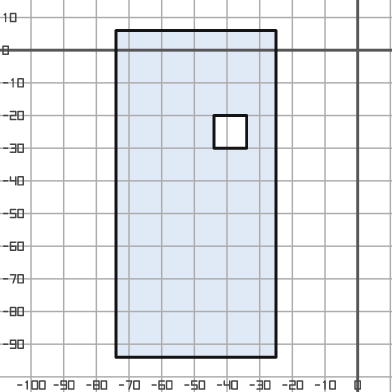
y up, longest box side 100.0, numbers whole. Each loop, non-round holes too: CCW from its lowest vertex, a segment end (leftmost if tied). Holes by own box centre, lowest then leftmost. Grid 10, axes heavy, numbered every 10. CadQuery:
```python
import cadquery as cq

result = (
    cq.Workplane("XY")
    .moveTo(-74.0, -94.0)
    .lineTo(-25.0, -94.0)
    .lineTo(-25.0, 6.0)
    .lineTo(-74.0, 6.0)
    .close()
    .moveTo(-44.0, -30.0)
    .lineTo(-34.0, -30.0)
    .lineTo(-34.0, -20.0)
    .lineTo(-44.0, -20.0)
    .close()
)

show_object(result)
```